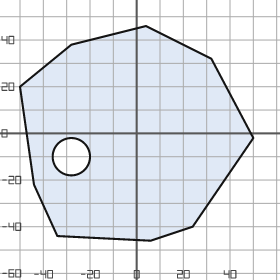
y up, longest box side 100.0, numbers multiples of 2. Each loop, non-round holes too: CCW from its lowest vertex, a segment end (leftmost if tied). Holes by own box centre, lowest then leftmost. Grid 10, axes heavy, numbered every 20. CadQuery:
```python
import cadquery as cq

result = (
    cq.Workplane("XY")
    .moveTo(6.0, -46.0)
    .lineTo(24.0, -40.0)
    .lineTo(50.0, -2.0)
    .lineTo(32.0, 32.0)
    .lineTo(4.0, 46.0)
    .lineTo(-28.0, 38.0)
    .lineTo(-50.0, 20.0)
    .lineTo(-44.0, -22.0)
    .lineTo(-34.0, -44.0)
    .close()
    .moveTo(-28.0, -10.0)
    .circle(8.0)
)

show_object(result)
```